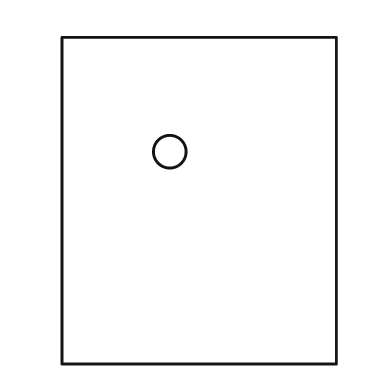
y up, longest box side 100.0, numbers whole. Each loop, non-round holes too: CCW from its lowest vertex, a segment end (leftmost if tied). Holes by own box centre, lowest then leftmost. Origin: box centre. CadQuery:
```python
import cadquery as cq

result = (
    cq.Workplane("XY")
    .moveTo(-42.0, -50.0)
    .lineTo(42.0, -50.0)
    .lineTo(42.0, 50.0)
    .lineTo(-42.0, 50.0)
    .close()
    .moveTo(-9.0, 15.0)
    .circle(5.0)
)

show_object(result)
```